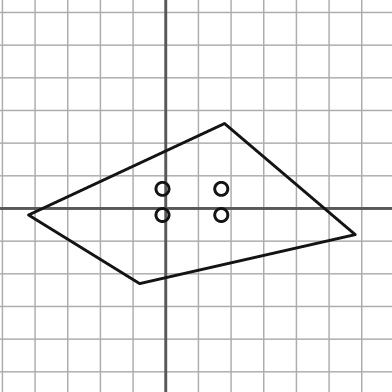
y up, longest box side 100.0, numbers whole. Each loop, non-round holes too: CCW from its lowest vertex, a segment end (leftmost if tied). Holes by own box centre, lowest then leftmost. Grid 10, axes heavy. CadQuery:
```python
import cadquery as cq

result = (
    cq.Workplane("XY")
    .moveTo(-8.0, -23.0)
    .lineTo(58.0, -8.0)
    .lineTo(18.0, 26.0)
    .lineTo(-42.0, -2.0)
    .close()
    .moveTo(-1.0, -2.0)
    .circle(2.0)
    .moveTo(17.0, -2.0)
    .circle(2.0)
    .moveTo(-1.0, 6.0)
    .circle(2.0)
    .moveTo(17.0, 6.0)
    .circle(2.0)
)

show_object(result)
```